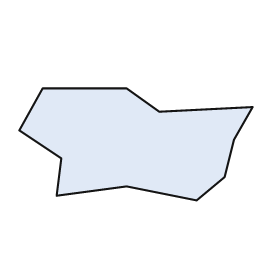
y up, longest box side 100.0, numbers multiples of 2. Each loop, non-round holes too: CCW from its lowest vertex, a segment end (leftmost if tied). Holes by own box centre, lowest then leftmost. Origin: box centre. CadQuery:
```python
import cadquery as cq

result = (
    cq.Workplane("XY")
    .moveTo(26.0, -24.0)
    .lineTo(38.0, -14.0)
    .lineTo(42.0, 2.0)
    .lineTo(50.0, 16.0)
    .lineTo(10.0, 14.0)
    .lineTo(-4.0, 24.0)
    .lineTo(-40.0, 24.0)
    .lineTo(-50.0, 6.0)
    .lineTo(-32.0, -6.0)
    .lineTo(-34.0, -22.0)
    .lineTo(-4.0, -18.0)
    .close()
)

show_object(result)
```